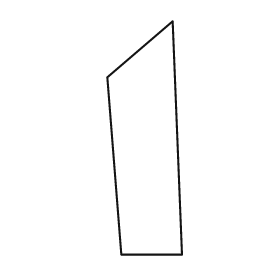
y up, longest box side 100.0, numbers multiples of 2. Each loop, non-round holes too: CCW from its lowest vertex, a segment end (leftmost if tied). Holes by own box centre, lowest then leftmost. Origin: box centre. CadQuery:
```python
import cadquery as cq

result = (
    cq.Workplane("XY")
    .moveTo(-10.0, -50.0)
    .lineTo(16.0, -50.0)
    .lineTo(12.0, 50.0)
    .lineTo(-16.0, 26.0)
    .close()
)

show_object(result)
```